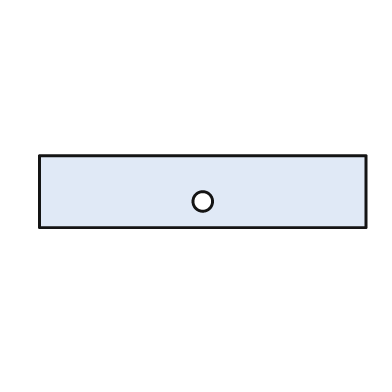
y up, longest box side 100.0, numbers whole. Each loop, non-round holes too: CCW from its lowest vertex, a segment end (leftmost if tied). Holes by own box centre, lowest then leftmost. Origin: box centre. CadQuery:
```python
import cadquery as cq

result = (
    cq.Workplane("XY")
    .moveTo(-50.0, -11.0)
    .lineTo(50.0, -11.0)
    .lineTo(50.0, 11.0)
    .lineTo(-50.0, 11.0)
    .close()
    .moveTo(0.0, -3.0)
    .circle(3.0)
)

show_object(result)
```